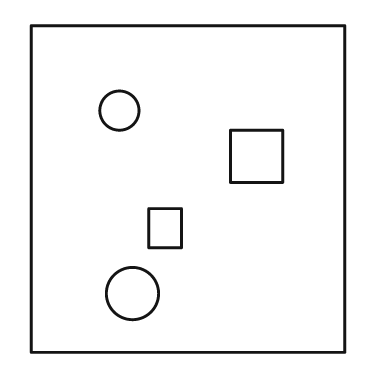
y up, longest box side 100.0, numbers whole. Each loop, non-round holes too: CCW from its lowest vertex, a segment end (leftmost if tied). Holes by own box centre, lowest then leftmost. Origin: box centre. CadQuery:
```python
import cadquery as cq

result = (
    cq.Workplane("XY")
    .moveTo(-48.0, -50.0)
    .lineTo(48.0, -50.0)
    .lineTo(48.0, 50.0)
    .lineTo(-48.0, 50.0)
    .close()
    .moveTo(-17.0, -32.0)
    .circle(8.0)
    .moveTo(-12.0, -18.0)
    .lineTo(-2.0, -18.0)
    .lineTo(-2.0, -6.0)
    .lineTo(-12.0, -6.0)
    .close()
    .moveTo(13.0, 2.0)
    .lineTo(29.0, 2.0)
    .lineTo(29.0, 18.0)
    .lineTo(13.0, 18.0)
    .close()
    .moveTo(-21.0, 24.0)
    .circle(6.0)
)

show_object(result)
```